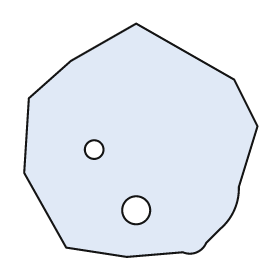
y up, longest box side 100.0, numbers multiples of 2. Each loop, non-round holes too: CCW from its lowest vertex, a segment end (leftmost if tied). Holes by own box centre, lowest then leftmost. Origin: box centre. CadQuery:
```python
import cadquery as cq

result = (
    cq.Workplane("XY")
    .moveTo(-6.0, -50.0)
    .lineTo(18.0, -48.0)
    .threePointArc((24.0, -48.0), (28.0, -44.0))
    .lineTo(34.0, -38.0)
    .threePointArc((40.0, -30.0), (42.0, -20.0))
    .lineTo(50.0, 6.0)
    .lineTo(40.0, 26.0)
    .lineTo(-2.0, 50.0)
    .lineTo(-30.0, 34.0)
    .lineTo(-48.0, 18.0)
    .lineTo(-50.0, -14.0)
    .lineTo(-32.0, -46.0)
    .close()
    .moveTo(-2.0, -30.0)
    .circle(6.0)
    .moveTo(-20.0, -4.0)
    .circle(4.0)
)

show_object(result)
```